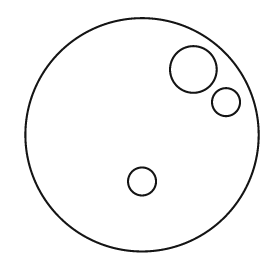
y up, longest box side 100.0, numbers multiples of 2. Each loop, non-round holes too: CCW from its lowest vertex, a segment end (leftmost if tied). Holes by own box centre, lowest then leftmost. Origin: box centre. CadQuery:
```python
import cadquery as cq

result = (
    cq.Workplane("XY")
    .moveTo(0.0, 0.0)
    .circle(50.0)
    .moveTo(0.0, -20.0)
    .circle(6.0)
    .moveTo(36.0, 14.0)
    .circle(6.0)
    .moveTo(22.0, 28.0)
    .circle(10.0)
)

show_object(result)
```